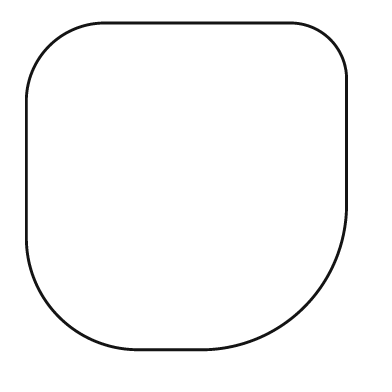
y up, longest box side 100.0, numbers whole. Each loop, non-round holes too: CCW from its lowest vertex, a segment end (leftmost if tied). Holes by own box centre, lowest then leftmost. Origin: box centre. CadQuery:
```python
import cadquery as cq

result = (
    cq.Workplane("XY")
    .moveTo(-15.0, -50.0)
    .lineTo(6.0, -50.0)
    .threePointArc((36.0, -37.0), (49.0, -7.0))
    .lineTo(49.0, 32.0)
    .threePointArc((44.0, 45.0), (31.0, 50.0))
    .lineTo(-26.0, 50.0)
    .threePointArc((-42.0, 43.0), (-49.0, 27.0))
    .lineTo(-49.0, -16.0)
    .threePointArc((-39.0, -40.0), (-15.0, -50.0))
    .close()
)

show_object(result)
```